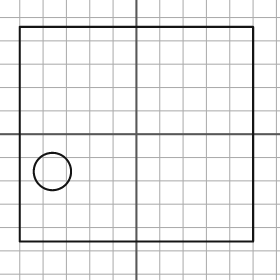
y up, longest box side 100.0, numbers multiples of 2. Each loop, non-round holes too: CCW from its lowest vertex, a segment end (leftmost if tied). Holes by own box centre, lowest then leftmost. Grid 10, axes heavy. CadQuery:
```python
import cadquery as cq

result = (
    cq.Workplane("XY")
    .moveTo(-50.0, -46.0)
    .lineTo(50.0, -46.0)
    .lineTo(50.0, 46.0)
    .lineTo(-50.0, 46.0)
    .close()
    .moveTo(-36.0, -16.0)
    .circle(8.0)
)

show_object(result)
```